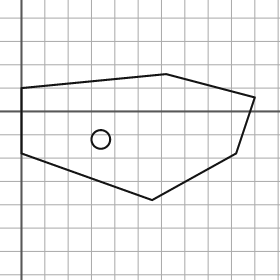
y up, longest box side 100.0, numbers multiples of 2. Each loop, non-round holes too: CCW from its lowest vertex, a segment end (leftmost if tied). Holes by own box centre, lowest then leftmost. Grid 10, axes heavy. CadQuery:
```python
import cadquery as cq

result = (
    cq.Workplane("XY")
    .moveTo(56.0, -38.0)
    .lineTo(92.0, -18.0)
    .lineTo(100.0, 6.0)
    .lineTo(62.0, 16.0)
    .lineTo(0.0, 10.0)
    .lineTo(0.0, -18.0)
    .close()
    .moveTo(34.0, -12.0)
    .circle(4.0)
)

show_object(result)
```